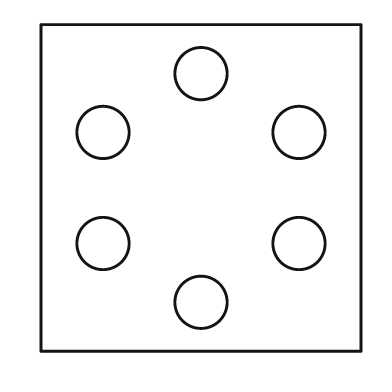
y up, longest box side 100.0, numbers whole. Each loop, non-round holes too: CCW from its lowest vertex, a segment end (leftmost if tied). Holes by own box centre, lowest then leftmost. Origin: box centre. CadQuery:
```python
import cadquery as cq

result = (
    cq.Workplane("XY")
    .moveTo(-49.0, -50.0)
    .lineTo(49.0, -50.0)
    .lineTo(49.0, 50.0)
    .lineTo(-49.0, 50.0)
    .close()
    .moveTo(0.0, -35.0)
    .circle(8.0)
    .moveTo(-30.0, -17.0)
    .circle(8.0)
    .moveTo(30.0, -17.0)
    .circle(8.0)
    .moveTo(-30.0, 17.0)
    .circle(8.0)
    .moveTo(30.0, 17.0)
    .circle(8.0)
    .moveTo(0.0, 35.0)
    .circle(8.0)
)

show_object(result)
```